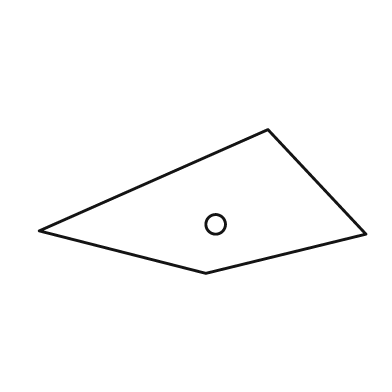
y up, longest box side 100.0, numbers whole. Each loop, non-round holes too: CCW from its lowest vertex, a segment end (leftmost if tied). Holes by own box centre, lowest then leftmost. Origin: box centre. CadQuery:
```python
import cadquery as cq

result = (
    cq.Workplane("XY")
    .moveTo(1.0, -22.0)
    .lineTo(50.0, -10.0)
    .lineTo(20.0, 22.0)
    .lineTo(-50.0, -9.0)
    .close()
    .moveTo(4.0, -7.0)
    .circle(3.0)
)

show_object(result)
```